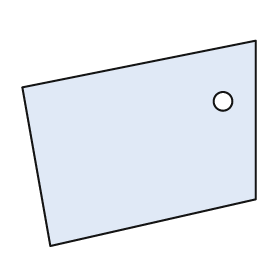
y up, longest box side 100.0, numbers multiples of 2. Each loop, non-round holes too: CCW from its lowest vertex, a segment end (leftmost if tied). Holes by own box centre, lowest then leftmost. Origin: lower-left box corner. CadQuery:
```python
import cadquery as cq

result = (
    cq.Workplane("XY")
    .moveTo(12.0, 0.0)
    .lineTo(100.0, 20.0)
    .lineTo(100.0, 88.0)
    .lineTo(0.0, 68.0)
    .close()
    .moveTo(86.0, 62.0)
    .circle(4.0)
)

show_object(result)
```